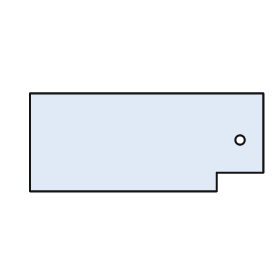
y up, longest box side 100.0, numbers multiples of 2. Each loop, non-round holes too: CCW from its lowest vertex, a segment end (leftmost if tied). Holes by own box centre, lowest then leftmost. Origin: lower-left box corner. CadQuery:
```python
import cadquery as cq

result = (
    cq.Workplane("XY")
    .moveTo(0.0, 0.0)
    .lineTo(80.0, 0.0)
    .lineTo(80.0, 8.0)
    .lineTo(100.0, 8.0)
    .lineTo(100.0, 42.0)
    .lineTo(0.0, 42.0)
    .close()
    .moveTo(90.0, 22.0)
    .circle(2.0)
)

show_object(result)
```